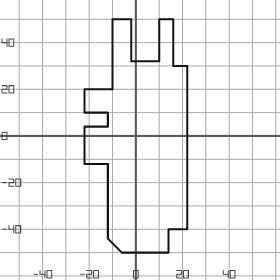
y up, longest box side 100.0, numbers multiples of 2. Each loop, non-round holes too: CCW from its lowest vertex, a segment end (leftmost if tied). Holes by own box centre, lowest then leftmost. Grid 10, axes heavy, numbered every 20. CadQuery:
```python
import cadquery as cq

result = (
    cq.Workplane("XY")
    .moveTo(-6.0, -50.0)
    .lineTo(14.0, -50.0)
    .lineTo(14.0, -40.0)
    .lineTo(22.0, -40.0)
    .lineTo(22.0, 30.0)
    .lineTo(16.0, 30.0)
    .lineTo(16.0, 50.0)
    .lineTo(10.0, 50.0)
    .lineTo(10.0, 32.0)
    .lineTo(-2.0, 32.0)
    .lineTo(-2.0, 50.0)
    .lineTo(-10.0, 50.0)
    .lineTo(-10.0, 20.0)
    .lineTo(-22.0, 20.0)
    .lineTo(-22.0, 10.0)
    .lineTo(-12.0, 10.0)
    .lineTo(-12.0, 4.0)
    .lineTo(-22.0, 4.0)
    .lineTo(-22.0, -12.0)
    .lineTo(-12.0, -12.0)
    .lineTo(-12.0, -44.0)
    .close()
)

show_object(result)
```